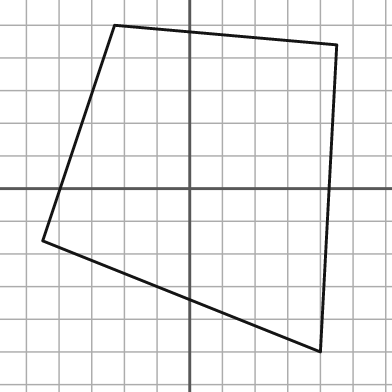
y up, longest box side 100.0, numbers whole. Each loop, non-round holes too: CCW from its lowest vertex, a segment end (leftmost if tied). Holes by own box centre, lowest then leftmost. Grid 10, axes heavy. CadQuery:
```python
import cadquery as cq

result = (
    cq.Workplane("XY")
    .moveTo(40.0, -50.0)
    .lineTo(45.0, 44.0)
    .lineTo(-23.0, 50.0)
    .lineTo(-45.0, -16.0)
    .close()
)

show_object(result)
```